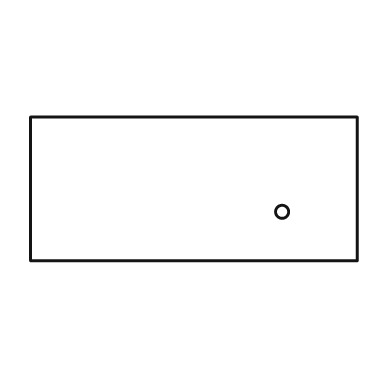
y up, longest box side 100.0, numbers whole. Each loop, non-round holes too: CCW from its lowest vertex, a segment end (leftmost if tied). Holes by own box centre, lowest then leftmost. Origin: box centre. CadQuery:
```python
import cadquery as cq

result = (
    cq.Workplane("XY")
    .moveTo(-50.0, -22.0)
    .lineTo(50.0, -22.0)
    .lineTo(50.0, 22.0)
    .lineTo(-50.0, 22.0)
    .close()
    .moveTo(27.0, -7.0)
    .circle(2.0)
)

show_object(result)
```